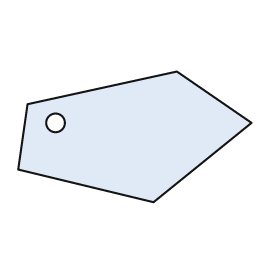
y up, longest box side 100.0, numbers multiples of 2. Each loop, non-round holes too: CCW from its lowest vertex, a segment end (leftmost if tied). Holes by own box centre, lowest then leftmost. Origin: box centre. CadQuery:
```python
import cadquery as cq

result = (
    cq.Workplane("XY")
    .moveTo(8.0, -28.0)
    .lineTo(50.0, 6.0)
    .lineTo(18.0, 28.0)
    .lineTo(-46.0, 14.0)
    .lineTo(-50.0, -14.0)
    .close()
    .moveTo(-34.0, 6.0)
    .circle(4.0)
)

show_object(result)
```